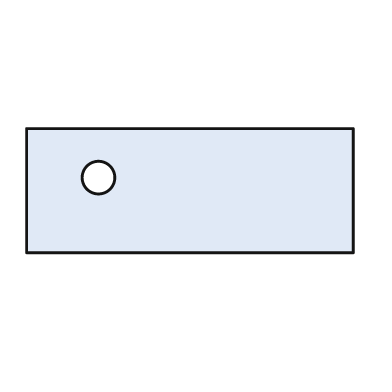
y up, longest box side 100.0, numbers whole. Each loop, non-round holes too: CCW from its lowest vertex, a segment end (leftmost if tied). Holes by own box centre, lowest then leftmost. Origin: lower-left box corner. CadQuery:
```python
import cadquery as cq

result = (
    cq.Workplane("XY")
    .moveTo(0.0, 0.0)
    .lineTo(100.0, 0.0)
    .lineTo(100.0, 38.0)
    .lineTo(0.0, 38.0)
    .close()
    .moveTo(22.0, 23.0)
    .circle(5.0)
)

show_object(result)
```